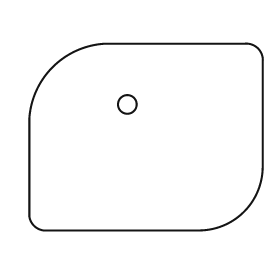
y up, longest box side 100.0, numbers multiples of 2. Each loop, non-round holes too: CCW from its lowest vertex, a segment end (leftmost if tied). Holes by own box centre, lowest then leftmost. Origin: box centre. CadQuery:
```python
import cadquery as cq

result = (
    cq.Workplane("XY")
    .moveTo(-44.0, -40.0)
    .lineTo(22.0, -40.0)
    .threePointArc((42.0, -32.0), (50.0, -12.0))
    .lineTo(50.0, 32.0)
    .threePointArc((48.0, 38.0), (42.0, 40.0))
    .lineTo(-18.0, 40.0)
    .threePointArc((-40.0, 30.0), (-50.0, 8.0))
    .lineTo(-50.0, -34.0)
    .threePointArc((-48.0, -38.0), (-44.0, -40.0))
    .close()
    .moveTo(-8.0, 14.0)
    .circle(4.0)
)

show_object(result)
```